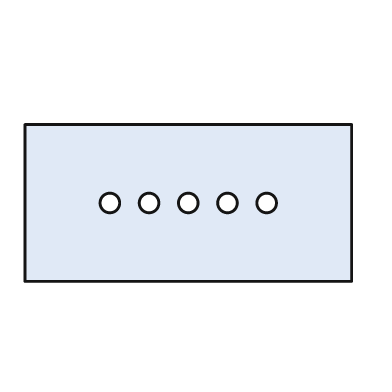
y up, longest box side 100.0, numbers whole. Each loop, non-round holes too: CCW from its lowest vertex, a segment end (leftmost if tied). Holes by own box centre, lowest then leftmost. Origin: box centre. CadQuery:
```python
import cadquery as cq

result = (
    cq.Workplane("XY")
    .moveTo(-50.0, -24.0)
    .lineTo(50.0, -24.0)
    .lineTo(50.0, 24.0)
    .lineTo(-50.0, 24.0)
    .close()
    .moveTo(-24.0, 0.0)
    .circle(3.0)
    .moveTo(-12.0, 0.0)
    .circle(3.0)
    .moveTo(0.0, 0.0)
    .circle(3.0)
    .moveTo(12.0, 0.0)
    .circle(3.0)
    .moveTo(24.0, 0.0)
    .circle(3.0)
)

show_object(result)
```